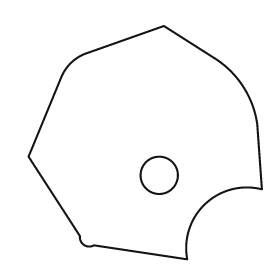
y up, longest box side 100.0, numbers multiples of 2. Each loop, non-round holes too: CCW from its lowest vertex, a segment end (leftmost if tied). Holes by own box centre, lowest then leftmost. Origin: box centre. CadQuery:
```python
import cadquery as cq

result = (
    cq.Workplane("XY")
    .moveTo(18.0, -50.0)
    .threePointArc((26.0, -26.0), (50.0, -20.0))
    .lineTo(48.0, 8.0)
    .threePointArc((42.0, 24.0), (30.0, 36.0))
    .lineTo(8.0, 50.0)
    .lineTo(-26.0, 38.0)
    .threePointArc((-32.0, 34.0), (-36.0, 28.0))
    .lineTo(-50.0, -6.0)
    .lineTo(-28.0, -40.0)
    .threePointArc((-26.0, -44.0), (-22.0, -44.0))
    .close()
    .moveTo(6.0, -14.0)
    .circle(8.0)
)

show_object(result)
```